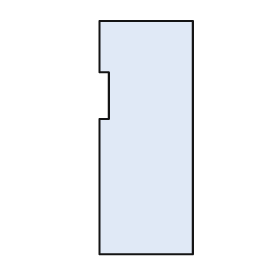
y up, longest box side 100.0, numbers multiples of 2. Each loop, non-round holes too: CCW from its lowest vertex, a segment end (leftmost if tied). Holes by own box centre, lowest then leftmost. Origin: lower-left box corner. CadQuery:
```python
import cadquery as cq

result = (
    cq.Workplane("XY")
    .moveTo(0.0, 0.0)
    .lineTo(40.0, 0.0)
    .lineTo(40.0, 100.0)
    .lineTo(0.0, 100.0)
    .lineTo(0.0, 78.0)
    .lineTo(4.0, 78.0)
    .lineTo(4.0, 58.0)
    .lineTo(0.0, 58.0)
    .close()
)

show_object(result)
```